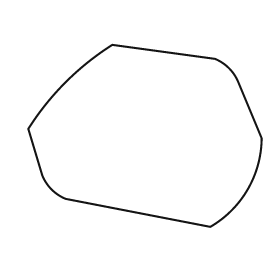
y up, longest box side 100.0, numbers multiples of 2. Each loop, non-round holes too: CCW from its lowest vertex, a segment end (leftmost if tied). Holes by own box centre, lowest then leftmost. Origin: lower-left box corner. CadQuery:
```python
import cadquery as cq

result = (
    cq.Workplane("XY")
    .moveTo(78.0, 0.0)
    .threePointArc((94.0, 16.0), (100.0, 38.0))
    .lineTo(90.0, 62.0)
    .threePointArc((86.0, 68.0), (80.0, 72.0))
    .lineTo(36.0, 78.0)
    .threePointArc((16.0, 62.0), (0.0, 42.0))
    .lineTo(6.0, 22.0)
    .threePointArc((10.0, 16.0), (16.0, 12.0))
    .close()
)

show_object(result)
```